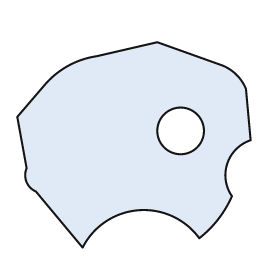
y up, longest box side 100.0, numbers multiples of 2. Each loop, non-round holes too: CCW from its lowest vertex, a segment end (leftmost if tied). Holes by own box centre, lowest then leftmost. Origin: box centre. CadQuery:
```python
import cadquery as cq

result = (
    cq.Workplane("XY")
    .moveTo(-22.0, -44.0)
    .threePointArc((2.0, -28.0), (28.0, -40.0))
    .threePointArc((36.0, -32.0), (42.0, -22.0))
    .threePointArc((40.0, -8.0), (50.0, 2.0))
    .lineTo(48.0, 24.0)
    .threePointArc((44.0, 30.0), (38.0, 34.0))
    .lineTo(10.0, 44.0)
    .lineTo(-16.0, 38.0)
    .threePointArc((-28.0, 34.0), (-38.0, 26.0))
    .lineTo(-50.0, 12.0)
    .lineTo(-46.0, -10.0)
    .threePointArc((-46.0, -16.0), (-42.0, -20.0))
    .close()
    .moveTo(20.0, 6.0)
    .circle(10.0)
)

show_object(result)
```